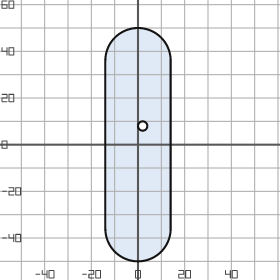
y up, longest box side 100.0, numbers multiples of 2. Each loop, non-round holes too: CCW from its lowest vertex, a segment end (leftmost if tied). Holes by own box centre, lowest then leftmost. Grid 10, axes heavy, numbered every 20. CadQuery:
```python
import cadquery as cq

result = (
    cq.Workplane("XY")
    .moveTo(-14.0, -36.0)
    .threePointArc((0.0, -50.0), (14.0, -36.0))
    .lineTo(14.0, 36.0)
    .threePointArc((0.0, 50.0), (-14.0, 36.0))
    .close()
    .moveTo(2.0, 8.0)
    .circle(2.0)
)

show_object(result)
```